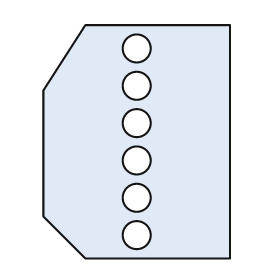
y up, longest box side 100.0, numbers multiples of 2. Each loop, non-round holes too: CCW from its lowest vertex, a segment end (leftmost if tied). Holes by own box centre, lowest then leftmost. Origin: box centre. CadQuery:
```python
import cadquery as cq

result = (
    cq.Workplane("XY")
    .moveTo(-22.0, -50.0)
    .lineTo(40.0, -50.0)
    .lineTo(40.0, 50.0)
    .lineTo(-22.0, 50.0)
    .lineTo(-40.0, 22.0)
    .lineTo(-40.0, -32.0)
    .close()
    .moveTo(0.0, -40.0)
    .circle(6.0)
    .moveTo(0.0, -24.0)
    .circle(6.0)
    .moveTo(0.0, -8.0)
    .circle(6.0)
    .moveTo(0.0, 8.0)
    .circle(6.0)
    .moveTo(0.0, 24.0)
    .circle(6.0)
    .moveTo(0.0, 40.0)
    .circle(6.0)
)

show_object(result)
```